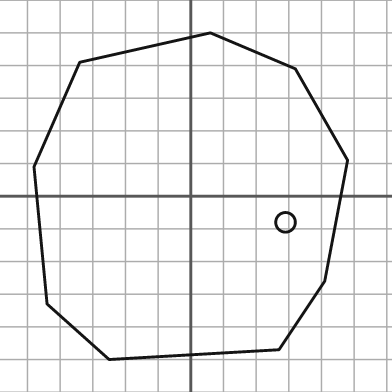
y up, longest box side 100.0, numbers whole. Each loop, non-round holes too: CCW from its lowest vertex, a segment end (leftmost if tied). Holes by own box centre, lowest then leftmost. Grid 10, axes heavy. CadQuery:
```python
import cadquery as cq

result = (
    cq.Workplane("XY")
    .moveTo(-25.0, -50.0)
    .lineTo(27.0, -47.0)
    .lineTo(41.0, -26.0)
    .lineTo(48.0, 11.0)
    .lineTo(32.0, 39.0)
    .lineTo(6.0, 50.0)
    .lineTo(-34.0, 41.0)
    .lineTo(-48.0, 9.0)
    .lineTo(-44.0, -33.0)
    .close()
    .moveTo(29.0, -8.0)
    .circle(3.0)
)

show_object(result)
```